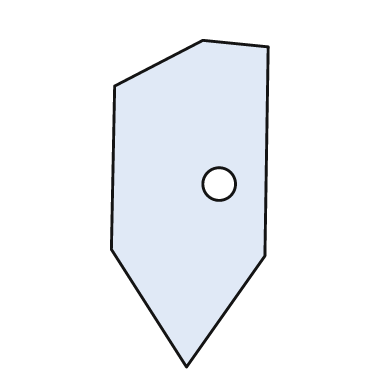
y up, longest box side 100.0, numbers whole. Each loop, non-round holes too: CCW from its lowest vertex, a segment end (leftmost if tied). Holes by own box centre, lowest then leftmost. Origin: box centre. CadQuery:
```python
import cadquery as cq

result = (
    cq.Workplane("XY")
    .moveTo(-1.0, -50.0)
    .lineTo(23.0, -16.0)
    .lineTo(24.0, 48.0)
    .lineTo(4.0, 50.0)
    .lineTo(-23.0, 36.0)
    .lineTo(-24.0, -14.0)
    .close()
    .moveTo(9.0, 6.0)
    .circle(5.0)
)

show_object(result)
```